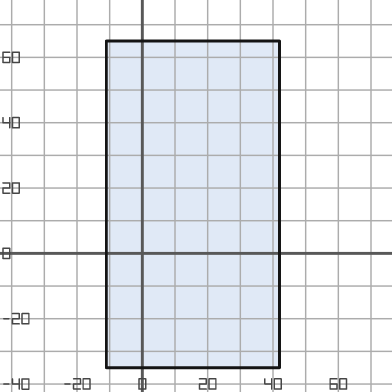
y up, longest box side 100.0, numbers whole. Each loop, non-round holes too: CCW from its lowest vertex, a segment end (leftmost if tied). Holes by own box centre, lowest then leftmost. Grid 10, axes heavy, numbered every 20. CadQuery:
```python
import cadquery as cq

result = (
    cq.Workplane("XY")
    .moveTo(-11.0, -35.0)
    .lineTo(42.0, -35.0)
    .lineTo(42.0, 65.0)
    .lineTo(-11.0, 65.0)
    .close()
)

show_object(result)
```